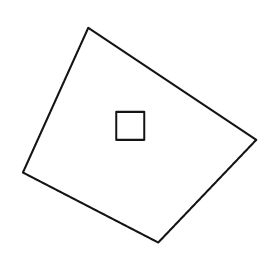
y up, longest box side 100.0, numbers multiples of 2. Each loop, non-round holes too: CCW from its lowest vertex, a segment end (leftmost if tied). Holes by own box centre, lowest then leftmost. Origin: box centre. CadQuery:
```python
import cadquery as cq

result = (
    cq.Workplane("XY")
    .moveTo(8.0, -46.0)
    .lineTo(50.0, -2.0)
    .lineTo(-22.0, 46.0)
    .lineTo(-50.0, -16.0)
    .close()
    .moveTo(-10.0, -2.0)
    .lineTo(2.0, -2.0)
    .lineTo(2.0, 10.0)
    .lineTo(-10.0, 10.0)
    .close()
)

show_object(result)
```